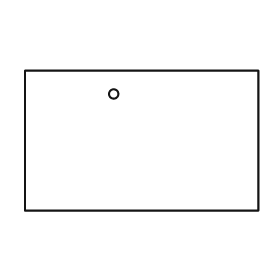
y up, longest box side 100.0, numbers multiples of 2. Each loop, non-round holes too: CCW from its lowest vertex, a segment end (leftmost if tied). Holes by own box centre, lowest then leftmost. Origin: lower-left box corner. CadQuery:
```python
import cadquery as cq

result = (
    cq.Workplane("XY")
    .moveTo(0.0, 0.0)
    .lineTo(100.0, 0.0)
    .lineTo(100.0, 60.0)
    .lineTo(0.0, 60.0)
    .close()
    .moveTo(38.0, 50.0)
    .circle(2.0)
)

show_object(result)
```